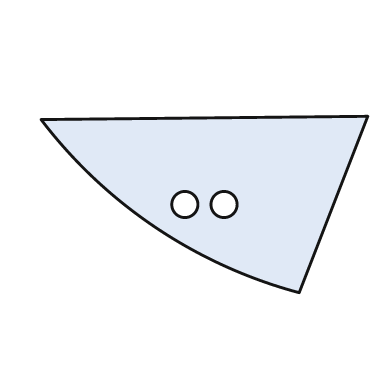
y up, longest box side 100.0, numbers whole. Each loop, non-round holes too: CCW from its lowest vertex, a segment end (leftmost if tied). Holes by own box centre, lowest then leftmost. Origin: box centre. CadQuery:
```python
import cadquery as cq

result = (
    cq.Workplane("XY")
    .moveTo(29.0, -27.0)
    .lineTo(50.0, 27.0)
    .lineTo(-50.0, 26.0)
    .threePointArc((-15.0, -7.0), (29.0, -27.0))
    .close()
    .moveTo(-6.0, 0.0)
    .circle(4.0)
    .moveTo(6.0, 0.0)
    .circle(4.0)
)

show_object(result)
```